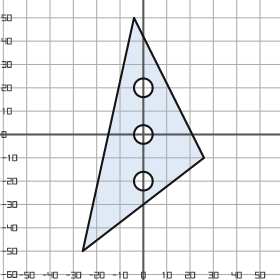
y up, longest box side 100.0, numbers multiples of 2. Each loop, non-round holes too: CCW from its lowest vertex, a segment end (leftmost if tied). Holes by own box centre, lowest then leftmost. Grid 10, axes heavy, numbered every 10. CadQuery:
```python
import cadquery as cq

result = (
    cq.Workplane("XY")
    .moveTo(-26.0, -50.0)
    .lineTo(26.0, -10.0)
    .lineTo(-4.0, 50.0)
    .close()
    .moveTo(0.0, -20.0)
    .circle(4.0)
    .moveTo(0.0, 0.0)
    .circle(4.0)
    .moveTo(0.0, 20.0)
    .circle(4.0)
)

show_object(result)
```